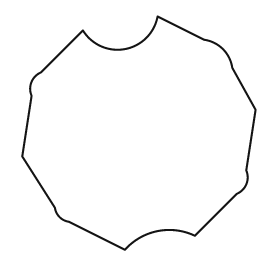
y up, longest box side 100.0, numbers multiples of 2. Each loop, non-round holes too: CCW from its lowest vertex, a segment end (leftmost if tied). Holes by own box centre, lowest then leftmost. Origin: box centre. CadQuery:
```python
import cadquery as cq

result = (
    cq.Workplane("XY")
    .moveTo(-6.0, -50.0)
    .threePointArc((8.0, -42.0), (24.0, -44.0))
    .lineTo(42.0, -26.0)
    .threePointArc((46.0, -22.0), (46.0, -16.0))
    .lineTo(50.0, 10.0)
    .lineTo(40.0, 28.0)
    .threePointArc((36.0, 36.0), (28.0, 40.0))
    .lineTo(8.0, 50.0)
    .threePointArc((-6.0, 36.0), (-24.0, 44.0))
    .lineTo(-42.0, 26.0)
    .threePointArc((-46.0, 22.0), (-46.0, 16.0))
    .lineTo(-50.0, -10.0)
    .lineTo(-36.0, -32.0)
    .threePointArc((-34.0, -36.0), (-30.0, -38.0))
    .close()
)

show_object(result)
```